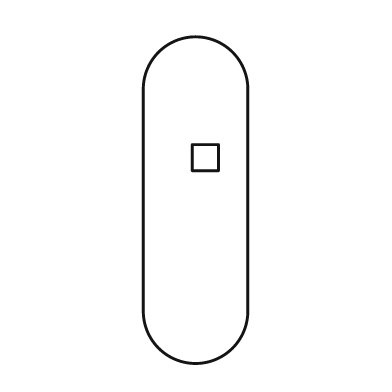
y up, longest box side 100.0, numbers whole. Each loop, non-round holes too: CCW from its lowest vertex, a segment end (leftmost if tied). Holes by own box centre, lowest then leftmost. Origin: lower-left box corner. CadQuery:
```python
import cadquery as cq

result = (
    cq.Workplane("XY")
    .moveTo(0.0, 16.0)
    .threePointArc((16.0, 0.0), (32.0, 16.0))
    .lineTo(32.0, 84.0)
    .threePointArc((16.0, 100.0), (0.0, 84.0))
    .close()
    .moveTo(15.0, 59.0)
    .lineTo(23.0, 59.0)
    .lineTo(23.0, 67.0)
    .lineTo(15.0, 67.0)
    .close()
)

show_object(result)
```